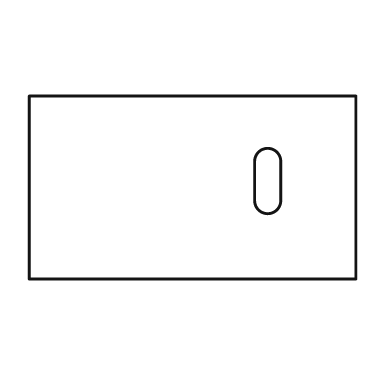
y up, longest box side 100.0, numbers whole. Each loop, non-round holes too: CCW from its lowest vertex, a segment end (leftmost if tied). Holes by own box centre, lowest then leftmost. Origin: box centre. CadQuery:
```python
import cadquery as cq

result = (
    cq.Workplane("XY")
    .moveTo(-50.0, -28.0)
    .lineTo(50.0, -28.0)
    .lineTo(50.0, 28.0)
    .lineTo(-50.0, 28.0)
    .close()
    .moveTo(19.0, -4.0)
    .threePointArc((23.0, -8.0), (27.0, -4.0))
    .lineTo(27.0, 8.0)
    .threePointArc((23.0, 12.0), (19.0, 8.0))
    .close()
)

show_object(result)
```